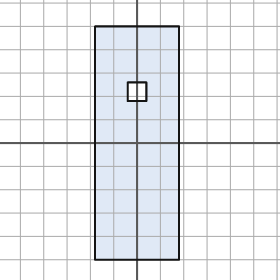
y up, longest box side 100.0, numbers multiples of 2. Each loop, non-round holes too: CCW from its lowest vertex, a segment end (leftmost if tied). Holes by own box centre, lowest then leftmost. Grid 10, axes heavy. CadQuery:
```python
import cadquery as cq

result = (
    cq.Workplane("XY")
    .moveTo(-18.0, -50.0)
    .lineTo(18.0, -50.0)
    .lineTo(18.0, 50.0)
    .lineTo(-18.0, 50.0)
    .close()
    .moveTo(-4.0, 18.0)
    .lineTo(4.0, 18.0)
    .lineTo(4.0, 26.0)
    .lineTo(-4.0, 26.0)
    .close()
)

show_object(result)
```